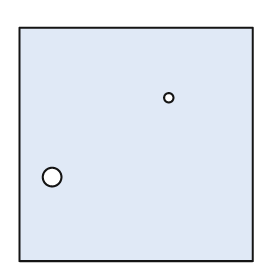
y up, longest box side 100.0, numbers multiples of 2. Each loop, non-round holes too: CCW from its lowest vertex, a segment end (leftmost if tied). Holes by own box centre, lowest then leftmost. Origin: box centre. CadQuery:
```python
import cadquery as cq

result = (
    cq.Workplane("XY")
    .moveTo(-50.0, -50.0)
    .lineTo(50.0, -50.0)
    .lineTo(50.0, 50.0)
    .lineTo(-50.0, 50.0)
    .close()
    .moveTo(-36.0, -14.0)
    .circle(4.0)
    .moveTo(14.0, 20.0)
    .circle(2.0)
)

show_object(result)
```